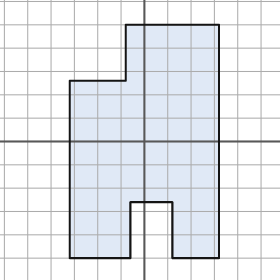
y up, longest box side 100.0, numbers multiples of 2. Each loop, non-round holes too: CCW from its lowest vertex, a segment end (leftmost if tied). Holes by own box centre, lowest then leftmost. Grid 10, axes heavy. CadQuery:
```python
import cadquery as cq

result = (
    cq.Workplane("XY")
    .moveTo(-32.0, -50.0)
    .lineTo(-6.0, -50.0)
    .lineTo(-6.0, -26.0)
    .lineTo(12.0, -26.0)
    .lineTo(12.0, -50.0)
    .lineTo(32.0, -50.0)
    .lineTo(32.0, 50.0)
    .lineTo(-8.0, 50.0)
    .lineTo(-8.0, 26.0)
    .lineTo(-32.0, 26.0)
    .close()
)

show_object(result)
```